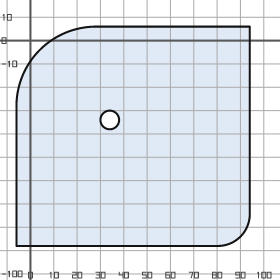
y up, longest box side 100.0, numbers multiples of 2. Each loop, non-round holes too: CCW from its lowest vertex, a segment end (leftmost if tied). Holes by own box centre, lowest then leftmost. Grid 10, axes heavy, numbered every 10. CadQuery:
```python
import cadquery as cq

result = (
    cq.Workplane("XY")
    .moveTo(-6.0, -88.0)
    .lineTo(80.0, -88.0)
    .threePointArc((90.0, -84.0), (94.0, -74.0))
    .lineTo(94.0, 6.0)
    .lineTo(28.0, 6.0)
    .threePointArc((4.0, -4.0), (-6.0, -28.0))
    .close()
    .moveTo(34.0, -34.0)
    .circle(4.0)
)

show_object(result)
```